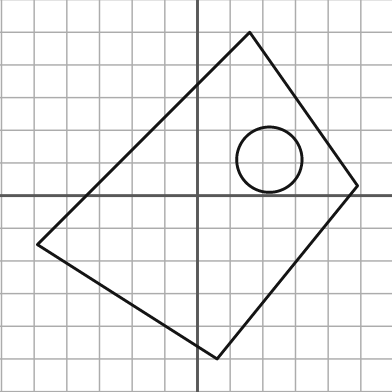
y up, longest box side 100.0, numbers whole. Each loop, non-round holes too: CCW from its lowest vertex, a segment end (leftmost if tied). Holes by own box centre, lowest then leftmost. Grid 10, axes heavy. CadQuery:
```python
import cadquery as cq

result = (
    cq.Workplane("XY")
    .moveTo(6.0, -50.0)
    .lineTo(49.0, 3.0)
    .lineTo(16.0, 50.0)
    .lineTo(-49.0, -15.0)
    .close()
    .moveTo(22.0, 11.0)
    .circle(10.0)
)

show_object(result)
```